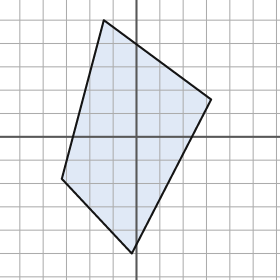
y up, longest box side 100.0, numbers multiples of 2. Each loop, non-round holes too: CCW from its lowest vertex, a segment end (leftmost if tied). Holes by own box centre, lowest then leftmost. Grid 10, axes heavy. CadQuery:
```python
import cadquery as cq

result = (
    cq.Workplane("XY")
    .moveTo(-2.0, -50.0)
    .lineTo(32.0, 16.0)
    .lineTo(-14.0, 50.0)
    .lineTo(-32.0, -18.0)
    .close()
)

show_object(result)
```